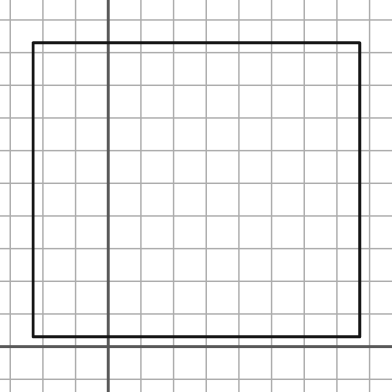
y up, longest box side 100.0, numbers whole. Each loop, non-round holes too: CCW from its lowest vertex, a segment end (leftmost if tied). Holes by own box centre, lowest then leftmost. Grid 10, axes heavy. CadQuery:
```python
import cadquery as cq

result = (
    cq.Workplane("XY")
    .moveTo(-23.0, 3.0)
    .lineTo(77.0, 3.0)
    .lineTo(77.0, 93.0)
    .lineTo(-23.0, 93.0)
    .close()
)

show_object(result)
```